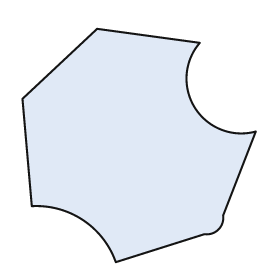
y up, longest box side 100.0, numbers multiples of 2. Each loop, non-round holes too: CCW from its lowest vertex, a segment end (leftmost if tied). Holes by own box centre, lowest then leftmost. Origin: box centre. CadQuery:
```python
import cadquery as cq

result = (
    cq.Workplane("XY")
    .moveTo(-10.0, -50.0)
    .lineTo(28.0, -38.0)
    .threePointArc((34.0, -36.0), (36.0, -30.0))
    .lineTo(50.0, 6.0)
    .threePointArc((24.0, 16.0), (26.0, 44.0))
    .lineTo(-18.0, 50.0)
    .lineTo(-50.0, 20.0)
    .lineTo(-46.0, -26.0)
    .threePointArc((-24.0, -32.0), (-10.0, -50.0))
    .close()
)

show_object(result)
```